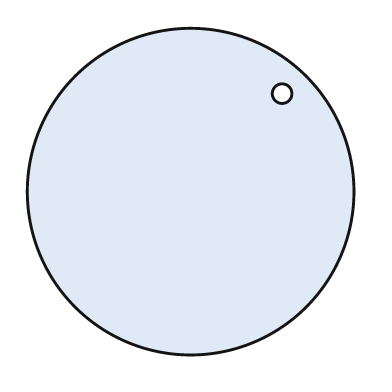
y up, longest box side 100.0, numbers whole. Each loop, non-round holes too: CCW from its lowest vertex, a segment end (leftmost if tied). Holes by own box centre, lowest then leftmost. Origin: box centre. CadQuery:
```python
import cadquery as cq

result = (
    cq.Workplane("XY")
    .moveTo(0.0, 0.0)
    .circle(50.0)
    .moveTo(28.0, 30.0)
    .circle(3.0)
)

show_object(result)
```